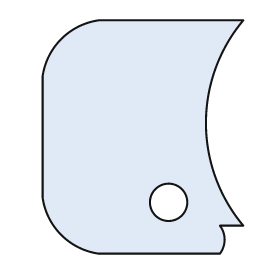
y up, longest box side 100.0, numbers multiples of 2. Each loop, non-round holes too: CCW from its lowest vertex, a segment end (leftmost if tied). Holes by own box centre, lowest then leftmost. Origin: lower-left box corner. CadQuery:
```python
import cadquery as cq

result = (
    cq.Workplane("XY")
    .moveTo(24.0, 0.0)
    .lineTo(76.0, 0.0)
    .threePointArc((78.0, 6.0), (76.0, 12.0))
    .lineTo(86.0, 12.0)
    .threePointArc((70.0, 56.0), (86.0, 100.0))
    .lineTo(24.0, 100.0)
    .threePointArc((8.0, 92.0), (0.0, 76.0))
    .lineTo(0.0, 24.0)
    .threePointArc((8.0, 8.0), (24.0, 0.0))
    .close()
    .moveTo(54.0, 22.0)
    .circle(8.0)
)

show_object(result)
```